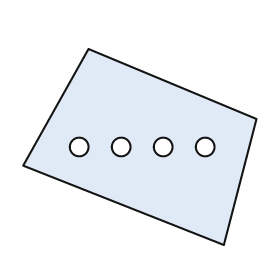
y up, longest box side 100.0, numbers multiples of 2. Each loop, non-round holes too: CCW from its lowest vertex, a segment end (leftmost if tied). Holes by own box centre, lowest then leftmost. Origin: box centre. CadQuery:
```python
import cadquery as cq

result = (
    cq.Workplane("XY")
    .moveTo(36.0, -42.0)
    .lineTo(50.0, 12.0)
    .lineTo(-22.0, 42.0)
    .lineTo(-50.0, -8.0)
    .close()
    .moveTo(-26.0, 0.0)
    .circle(4.0)
    .moveTo(-8.0, 0.0)
    .circle(4.0)
    .moveTo(10.0, 0.0)
    .circle(4.0)
    .moveTo(28.0, 0.0)
    .circle(4.0)
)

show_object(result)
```